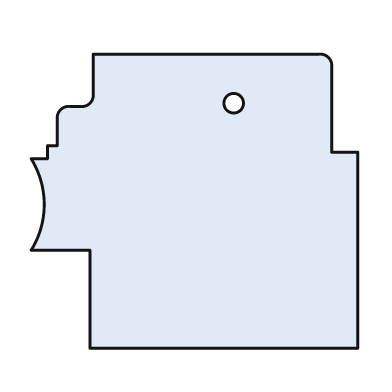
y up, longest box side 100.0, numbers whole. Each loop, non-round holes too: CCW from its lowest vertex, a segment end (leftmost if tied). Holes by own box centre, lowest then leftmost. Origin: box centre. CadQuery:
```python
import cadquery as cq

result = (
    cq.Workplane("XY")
    .moveTo(-32.0, -45.0)
    .lineTo(50.0, -45.0)
    .lineTo(50.0, 15.0)
    .lineTo(42.0, 15.0)
    .lineTo(42.0, 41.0)
    .threePointArc((41.0, 44.0), (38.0, 45.0))
    .lineTo(-31.0, 45.0)
    .lineTo(-31.0, 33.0)
    .threePointArc((-32.0, 30.0), (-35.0, 29.0))
    .lineTo(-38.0, 29.0)
    .threePointArc((-41.0, 28.0), (-42.0, 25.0))
    .lineTo(-42.0, 17.0)
    .lineTo(-45.0, 17.0)
    .lineTo(-45.0, 13.0)
    .lineTo(-50.0, 13.0)
    .threePointArc((-46.0, -1.0), (-50.0, -15.0))
    .lineTo(-32.0, -15.0)
    .close()
    .moveTo(12.0, 30.0)
    .circle(3.0)
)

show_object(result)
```